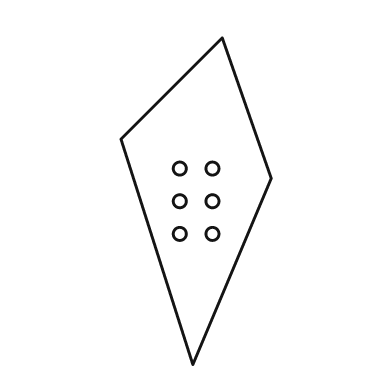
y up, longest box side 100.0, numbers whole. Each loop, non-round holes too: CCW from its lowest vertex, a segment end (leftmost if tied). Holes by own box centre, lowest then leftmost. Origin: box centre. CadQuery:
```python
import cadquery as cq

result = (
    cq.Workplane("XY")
    .moveTo(-1.0, -50.0)
    .lineTo(23.0, 7.0)
    .lineTo(8.0, 50.0)
    .lineTo(-23.0, 19.0)
    .close()
    .moveTo(-5.0, -10.0)
    .circle(2.0)
    .moveTo(5.0, -10.0)
    .circle(2.0)
    .moveTo(-5.0, 0.0)
    .circle(2.0)
    .moveTo(5.0, 0.0)
    .circle(2.0)
    .moveTo(-5.0, 10.0)
    .circle(2.0)
    .moveTo(5.0, 10.0)
    .circle(2.0)
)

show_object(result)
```